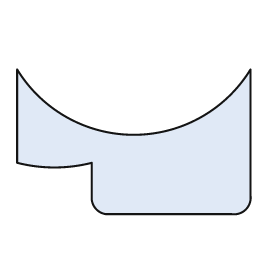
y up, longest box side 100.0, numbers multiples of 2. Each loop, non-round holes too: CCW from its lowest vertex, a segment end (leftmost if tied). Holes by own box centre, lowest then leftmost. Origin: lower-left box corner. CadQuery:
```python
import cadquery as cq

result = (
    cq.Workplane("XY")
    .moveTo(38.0, 0.0)
    .lineTo(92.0, 0.0)
    .threePointArc((98.0, 2.0), (100.0, 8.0))
    .lineTo(100.0, 62.0)
    .threePointArc((50.0, 34.0), (0.0, 62.0))
    .lineTo(0.0, 22.0)
    .threePointArc((16.0, 20.0), (32.0, 22.0))
    .lineTo(32.0, 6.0)
    .threePointArc((34.0, 2.0), (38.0, 0.0))
    .close()
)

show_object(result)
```